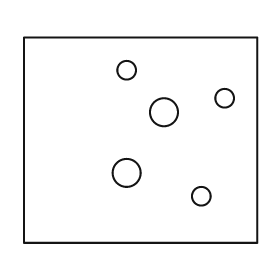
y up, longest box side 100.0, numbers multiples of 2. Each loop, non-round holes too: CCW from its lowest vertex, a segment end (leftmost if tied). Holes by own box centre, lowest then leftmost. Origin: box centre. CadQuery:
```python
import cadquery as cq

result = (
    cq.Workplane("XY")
    .moveTo(-50.0, -44.0)
    .lineTo(50.0, -44.0)
    .lineTo(50.0, 44.0)
    .lineTo(-50.0, 44.0)
    .close()
    .moveTo(26.0, -24.0)
    .circle(4.0)
    .moveTo(-6.0, -14.0)
    .circle(6.0)
    .moveTo(10.0, 12.0)
    .circle(6.0)
    .moveTo(36.0, 18.0)
    .circle(4.0)
    .moveTo(-6.0, 30.0)
    .circle(4.0)
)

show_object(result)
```